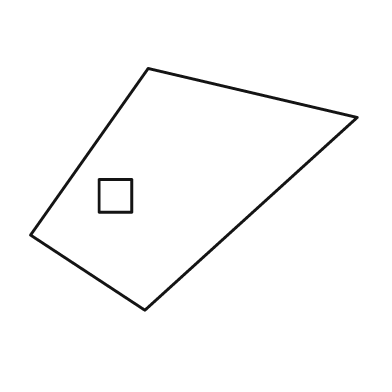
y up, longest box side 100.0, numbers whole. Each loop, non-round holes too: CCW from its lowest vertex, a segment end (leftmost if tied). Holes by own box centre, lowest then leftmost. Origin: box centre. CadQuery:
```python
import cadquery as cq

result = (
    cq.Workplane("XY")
    .moveTo(-15.0, -37.0)
    .lineTo(50.0, 22.0)
    .lineTo(-14.0, 37.0)
    .lineTo(-50.0, -14.0)
    .close()
    .moveTo(-29.0, -7.0)
    .lineTo(-19.0, -7.0)
    .lineTo(-19.0, 3.0)
    .lineTo(-29.0, 3.0)
    .close()
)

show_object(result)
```